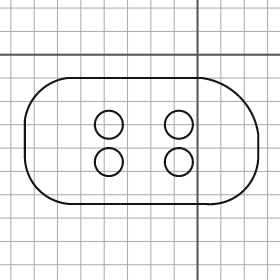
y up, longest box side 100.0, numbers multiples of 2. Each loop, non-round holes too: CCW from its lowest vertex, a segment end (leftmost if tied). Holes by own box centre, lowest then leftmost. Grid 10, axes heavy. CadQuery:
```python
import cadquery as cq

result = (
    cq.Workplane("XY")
    .moveTo(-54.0, -64.0)
    .lineTo(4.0, -64.0)
    .threePointArc((20.0, -58.0), (26.0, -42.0))
    .lineTo(26.0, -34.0)
    .threePointArc((18.0, -18.0), (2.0, -10.0))
    .lineTo(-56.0, -10.0)
    .threePointArc((-68.0, -16.0), (-74.0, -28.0))
    .lineTo(-74.0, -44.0)
    .threePointArc((-68.0, -58.0), (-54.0, -64.0))
    .close()
    .moveTo(-38.0, -46.0)
    .circle(6.0)
    .moveTo(-8.0, -46.0)
    .circle(6.0)
    .moveTo(-38.0, -30.0)
    .circle(6.0)
    .moveTo(-8.0, -30.0)
    .circle(6.0)
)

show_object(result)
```